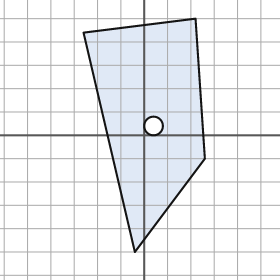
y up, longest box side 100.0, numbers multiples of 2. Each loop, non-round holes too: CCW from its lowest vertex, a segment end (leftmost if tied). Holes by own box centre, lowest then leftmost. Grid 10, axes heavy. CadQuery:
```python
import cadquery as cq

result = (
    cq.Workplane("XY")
    .moveTo(-4.0, -50.0)
    .lineTo(26.0, -10.0)
    .lineTo(22.0, 50.0)
    .lineTo(-26.0, 44.0)
    .close()
    .moveTo(4.0, 4.0)
    .circle(4.0)
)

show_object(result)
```